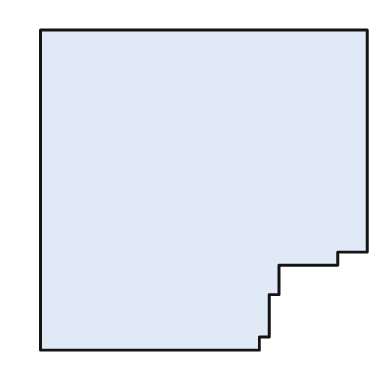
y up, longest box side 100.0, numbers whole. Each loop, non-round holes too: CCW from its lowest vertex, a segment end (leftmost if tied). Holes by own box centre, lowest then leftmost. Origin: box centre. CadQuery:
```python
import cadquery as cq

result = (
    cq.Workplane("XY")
    .moveTo(-50.0, -49.0)
    .lineTo(17.0, -49.0)
    .lineTo(17.0, -45.0)
    .lineTo(20.0, -45.0)
    .lineTo(20.0, -32.0)
    .lineTo(23.0, -32.0)
    .lineTo(23.0, -23.0)
    .lineTo(41.0, -23.0)
    .lineTo(41.0, -19.0)
    .lineTo(50.0, -19.0)
    .lineTo(50.0, 49.0)
    .lineTo(-50.0, 49.0)
    .close()
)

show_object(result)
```